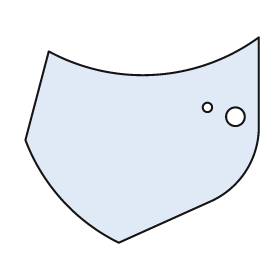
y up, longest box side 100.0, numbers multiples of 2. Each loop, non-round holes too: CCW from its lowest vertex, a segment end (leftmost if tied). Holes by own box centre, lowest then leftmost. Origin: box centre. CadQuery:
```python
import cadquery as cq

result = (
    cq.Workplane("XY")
    .moveTo(-10.0, -44.0)
    .lineTo(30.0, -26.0)
    .threePointArc((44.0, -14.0), (50.0, 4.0))
    .lineTo(50.0, 44.0)
    .threePointArc((6.0, 28.0), (-40.0, 38.0))
    .lineTo(-50.0, 0.0)
    .threePointArc((-34.0, -26.0), (-10.0, -44.0))
    .close()
    .moveTo(40.0, 10.0)
    .circle(4.0)
    .moveTo(28.0, 14.0)
    .circle(2.0)
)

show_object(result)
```